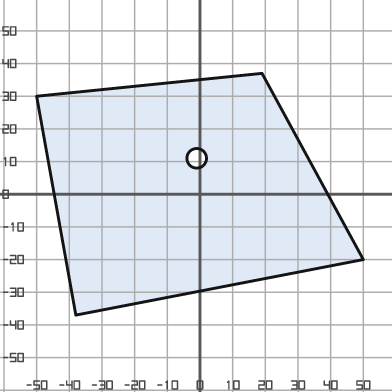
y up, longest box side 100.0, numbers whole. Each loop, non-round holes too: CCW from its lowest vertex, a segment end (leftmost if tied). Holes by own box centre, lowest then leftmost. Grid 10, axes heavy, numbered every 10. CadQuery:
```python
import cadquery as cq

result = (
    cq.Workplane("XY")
    .moveTo(-38.0, -37.0)
    .lineTo(50.0, -20.0)
    .lineTo(19.0, 37.0)
    .lineTo(-50.0, 30.0)
    .close()
    .moveTo(-1.0, 11.0)
    .circle(3.0)
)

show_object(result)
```